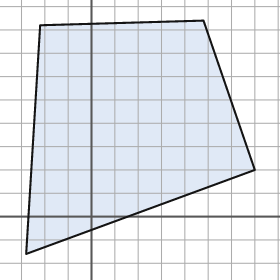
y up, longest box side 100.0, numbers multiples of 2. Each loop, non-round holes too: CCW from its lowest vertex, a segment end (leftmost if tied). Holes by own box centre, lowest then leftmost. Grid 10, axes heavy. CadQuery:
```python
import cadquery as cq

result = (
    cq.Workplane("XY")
    .moveTo(-28.0, -16.0)
    .lineTo(70.0, 20.0)
    .lineTo(48.0, 84.0)
    .lineTo(-22.0, 82.0)
    .close()
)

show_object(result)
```